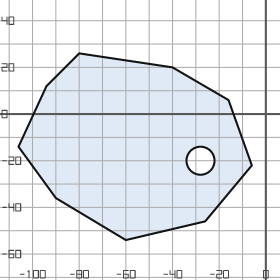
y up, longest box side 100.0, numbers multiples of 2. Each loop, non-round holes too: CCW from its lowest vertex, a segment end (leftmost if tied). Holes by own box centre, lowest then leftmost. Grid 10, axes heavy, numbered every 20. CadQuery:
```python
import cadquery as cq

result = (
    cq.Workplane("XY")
    .moveTo(-60.0, -54.0)
    .lineTo(-26.0, -46.0)
    .lineTo(-6.0, -22.0)
    .lineTo(-16.0, 6.0)
    .lineTo(-40.0, 20.0)
    .lineTo(-80.0, 26.0)
    .lineTo(-94.0, 12.0)
    .lineTo(-106.0, -14.0)
    .lineTo(-90.0, -36.0)
    .close()
    .moveTo(-28.0, -20.0)
    .circle(6.0)
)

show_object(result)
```